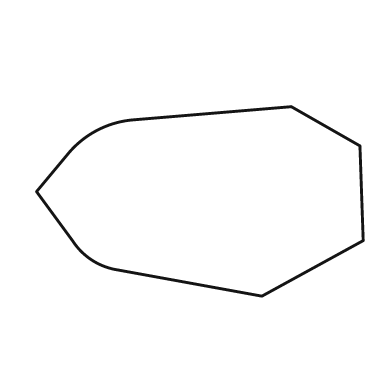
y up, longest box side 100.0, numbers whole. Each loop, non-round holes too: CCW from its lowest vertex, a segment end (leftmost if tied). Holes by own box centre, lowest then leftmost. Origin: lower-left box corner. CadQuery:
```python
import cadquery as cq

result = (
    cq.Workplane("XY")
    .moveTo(69.0, 0.0)
    .lineTo(100.0, 17.0)
    .lineTo(99.0, 46.0)
    .lineTo(78.0, 58.0)
    .lineTo(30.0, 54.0)
    .threePointArc((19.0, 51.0), (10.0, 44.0))
    .lineTo(0.0, 32.0)
    .lineTo(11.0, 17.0)
    .threePointArc((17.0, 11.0), (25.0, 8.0))
    .close()
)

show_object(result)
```